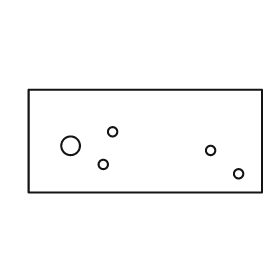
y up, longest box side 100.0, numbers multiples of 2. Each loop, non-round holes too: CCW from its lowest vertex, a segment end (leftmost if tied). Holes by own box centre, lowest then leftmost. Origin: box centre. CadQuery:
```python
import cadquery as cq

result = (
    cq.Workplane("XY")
    .moveTo(-50.0, -22.0)
    .lineTo(50.0, -22.0)
    .lineTo(50.0, 22.0)
    .lineTo(-50.0, 22.0)
    .close()
    .moveTo(40.0, -14.0)
    .circle(2.0)
    .moveTo(-18.0, -10.0)
    .circle(2.0)
    .moveTo(28.0, -4.0)
    .circle(2.0)
    .moveTo(-32.0, -2.0)
    .circle(4.0)
    .moveTo(-14.0, 4.0)
    .circle(2.0)
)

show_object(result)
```